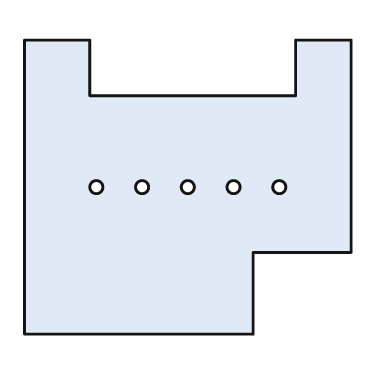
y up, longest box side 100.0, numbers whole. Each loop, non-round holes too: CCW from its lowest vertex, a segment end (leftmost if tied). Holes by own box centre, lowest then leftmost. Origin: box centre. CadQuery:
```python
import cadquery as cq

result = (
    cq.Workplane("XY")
    .moveTo(-50.0, -45.0)
    .lineTo(20.0, -45.0)
    .lineTo(20.0, -20.0)
    .lineTo(50.0, -20.0)
    .lineTo(50.0, 45.0)
    .lineTo(33.0, 45.0)
    .lineTo(33.0, 28.0)
    .lineTo(-30.0, 28.0)
    .lineTo(-30.0, 45.0)
    .lineTo(-50.0, 45.0)
    .close()
    .moveTo(-28.0, 0.0)
    .circle(2.0)
    .moveTo(-14.0, 0.0)
    .circle(2.0)
    .moveTo(0.0, 0.0)
    .circle(2.0)
    .moveTo(14.0, 0.0)
    .circle(2.0)
    .moveTo(28.0, 0.0)
    .circle(2.0)
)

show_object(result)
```